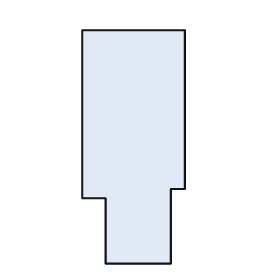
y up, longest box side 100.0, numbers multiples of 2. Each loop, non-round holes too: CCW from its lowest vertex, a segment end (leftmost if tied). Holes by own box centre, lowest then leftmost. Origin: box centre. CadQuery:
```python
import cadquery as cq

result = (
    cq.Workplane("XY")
    .moveTo(-12.0, -50.0)
    .lineTo(16.0, -50.0)
    .lineTo(16.0, -18.0)
    .lineTo(22.0, -18.0)
    .lineTo(22.0, 50.0)
    .lineTo(-22.0, 50.0)
    .lineTo(-22.0, -22.0)
    .lineTo(-12.0, -22.0)
    .close()
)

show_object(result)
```